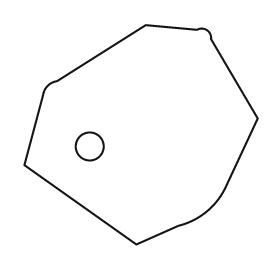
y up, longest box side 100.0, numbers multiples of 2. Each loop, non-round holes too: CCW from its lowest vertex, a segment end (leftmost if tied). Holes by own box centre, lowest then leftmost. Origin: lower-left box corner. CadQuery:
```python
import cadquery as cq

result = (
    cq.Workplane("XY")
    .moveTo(48.0, 0.0)
    .lineTo(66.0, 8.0)
    .threePointArc((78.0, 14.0), (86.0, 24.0))
    .lineTo(100.0, 54.0)
    .lineTo(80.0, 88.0)
    .threePointArc((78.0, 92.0), (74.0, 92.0))
    .lineTo(52.0, 94.0)
    .lineTo(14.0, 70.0)
    .threePointArc((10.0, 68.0), (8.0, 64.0))
    .lineTo(0.0, 34.0)
    .close()
    .moveTo(28.0, 42.0)
    .circle(6.0)
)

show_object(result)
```